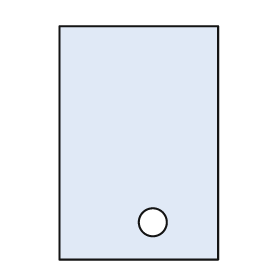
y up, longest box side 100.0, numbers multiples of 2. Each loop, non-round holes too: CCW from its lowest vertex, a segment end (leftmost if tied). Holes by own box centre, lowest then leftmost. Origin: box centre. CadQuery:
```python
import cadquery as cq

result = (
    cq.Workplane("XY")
    .moveTo(-34.0, -50.0)
    .lineTo(34.0, -50.0)
    .lineTo(34.0, 50.0)
    .lineTo(-34.0, 50.0)
    .close()
    .moveTo(6.0, -34.0)
    .circle(6.0)
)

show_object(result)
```